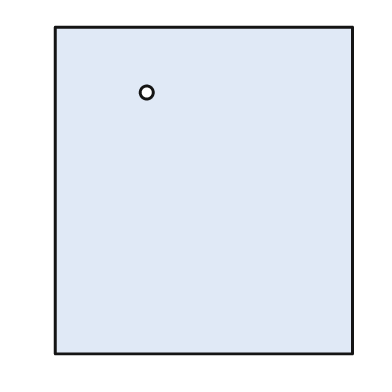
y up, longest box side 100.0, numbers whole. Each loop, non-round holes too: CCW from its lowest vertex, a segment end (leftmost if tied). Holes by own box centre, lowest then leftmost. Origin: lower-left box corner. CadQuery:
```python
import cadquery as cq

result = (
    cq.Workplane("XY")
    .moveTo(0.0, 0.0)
    .lineTo(91.0, 0.0)
    .lineTo(91.0, 100.0)
    .lineTo(0.0, 100.0)
    .close()
    .moveTo(28.0, 80.0)
    .circle(2.0)
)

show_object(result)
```